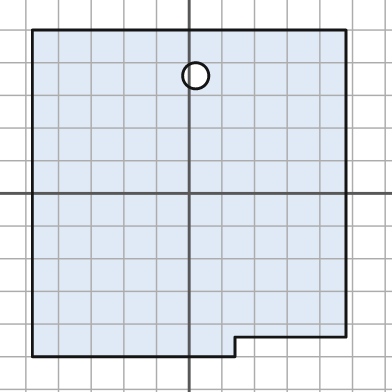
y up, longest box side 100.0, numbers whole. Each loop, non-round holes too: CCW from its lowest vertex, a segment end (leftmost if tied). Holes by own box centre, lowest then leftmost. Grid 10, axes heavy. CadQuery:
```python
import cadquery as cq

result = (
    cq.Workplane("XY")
    .moveTo(-48.0, -50.0)
    .lineTo(14.0, -50.0)
    .lineTo(14.0, -44.0)
    .lineTo(48.0, -44.0)
    .lineTo(48.0, 50.0)
    .lineTo(-48.0, 50.0)
    .close()
    .moveTo(2.0, 36.0)
    .circle(4.0)
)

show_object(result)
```